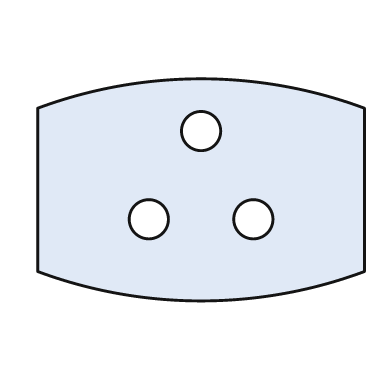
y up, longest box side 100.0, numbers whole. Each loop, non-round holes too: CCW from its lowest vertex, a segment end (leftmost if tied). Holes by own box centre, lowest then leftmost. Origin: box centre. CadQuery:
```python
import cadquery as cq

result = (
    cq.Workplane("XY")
    .moveTo(-50.0, -25.0)
    .threePointArc((0.0, -34.0), (50.0, -25.0))
    .lineTo(50.0, 25.0)
    .threePointArc((0.0, 34.0), (-50.0, 25.0))
    .close()
    .moveTo(-16.0, -9.0)
    .circle(6.0)
    .moveTo(16.0, -9.0)
    .circle(6.0)
    .moveTo(0.0, 18.0)
    .circle(6.0)
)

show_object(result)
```